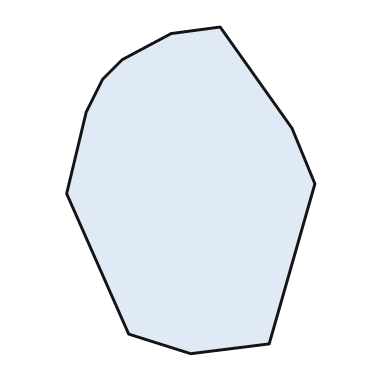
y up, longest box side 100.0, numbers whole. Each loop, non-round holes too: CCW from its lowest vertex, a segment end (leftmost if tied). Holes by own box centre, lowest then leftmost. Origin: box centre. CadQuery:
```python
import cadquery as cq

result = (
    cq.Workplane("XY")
    .moveTo(0.0, -50.0)
    .lineTo(24.0, -47.0)
    .lineTo(38.0, 2.0)
    .lineTo(31.0, 19.0)
    .lineTo(9.0, 50.0)
    .lineTo(-6.0, 48.0)
    .lineTo(-21.0, 40.0)
    .lineTo(-27.0, 34.0)
    .lineTo(-32.0, 24.0)
    .lineTo(-38.0, -1.0)
    .lineTo(-19.0, -44.0)
    .close()
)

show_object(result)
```